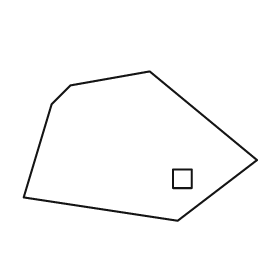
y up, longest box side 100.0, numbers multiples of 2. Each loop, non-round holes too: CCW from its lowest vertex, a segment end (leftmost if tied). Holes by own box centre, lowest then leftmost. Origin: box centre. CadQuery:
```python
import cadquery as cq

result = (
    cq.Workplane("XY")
    .moveTo(16.0, -32.0)
    .lineTo(50.0, -6.0)
    .lineTo(4.0, 32.0)
    .lineTo(-30.0, 26.0)
    .lineTo(-38.0, 18.0)
    .lineTo(-50.0, -22.0)
    .close()
    .moveTo(14.0, -18.0)
    .lineTo(22.0, -18.0)
    .lineTo(22.0, -10.0)
    .lineTo(14.0, -10.0)
    .close()
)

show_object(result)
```